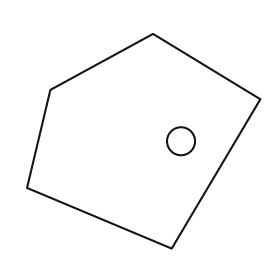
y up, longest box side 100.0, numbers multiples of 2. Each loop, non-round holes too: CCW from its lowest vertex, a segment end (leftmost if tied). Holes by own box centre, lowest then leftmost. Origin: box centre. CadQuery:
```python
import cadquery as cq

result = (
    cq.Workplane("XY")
    .moveTo(12.0, -46.0)
    .lineTo(50.0, 18.0)
    .lineTo(4.0, 46.0)
    .lineTo(-40.0, 22.0)
    .lineTo(-50.0, -20.0)
    .close()
    .moveTo(16.0, 0.0)
    .circle(6.0)
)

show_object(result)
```